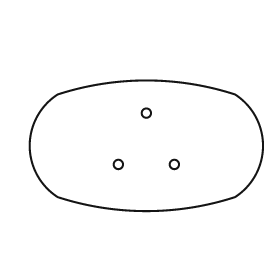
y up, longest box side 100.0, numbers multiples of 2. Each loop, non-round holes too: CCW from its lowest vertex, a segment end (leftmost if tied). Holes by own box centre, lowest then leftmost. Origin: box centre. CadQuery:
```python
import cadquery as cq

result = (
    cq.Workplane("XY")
    .moveTo(-38.0, -22.0)
    .threePointArc((0.0, -28.0), (38.0, -22.0))
    .threePointArc((50.0, 0.0), (38.0, 22.0))
    .threePointArc((0.0, 28.0), (-38.0, 22.0))
    .threePointArc((-50.0, 0.0), (-38.0, -22.0))
    .close()
    .moveTo(-12.0, -8.0)
    .circle(2.0)
    .moveTo(12.0, -8.0)
    .circle(2.0)
    .moveTo(0.0, 14.0)
    .circle(2.0)
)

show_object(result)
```